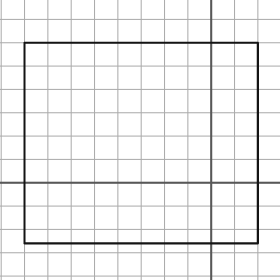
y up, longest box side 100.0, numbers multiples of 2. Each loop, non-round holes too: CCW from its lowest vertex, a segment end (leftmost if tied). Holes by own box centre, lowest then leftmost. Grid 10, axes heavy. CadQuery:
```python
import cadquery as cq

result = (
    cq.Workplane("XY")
    .moveTo(-80.0, -26.0)
    .lineTo(20.0, -26.0)
    .lineTo(20.0, 60.0)
    .lineTo(-80.0, 60.0)
    .close()
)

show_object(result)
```